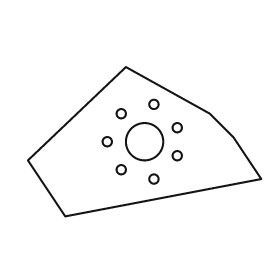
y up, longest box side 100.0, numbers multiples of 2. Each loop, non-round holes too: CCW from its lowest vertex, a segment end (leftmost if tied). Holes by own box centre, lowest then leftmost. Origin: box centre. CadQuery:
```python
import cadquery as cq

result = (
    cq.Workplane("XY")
    .moveTo(-34.0, -32.0)
    .lineTo(50.0, -16.0)
    .lineTo(38.0, 2.0)
    .lineTo(28.0, 12.0)
    .lineTo(-8.0, 32.0)
    .lineTo(-50.0, -8.0)
    .close()
    .moveTo(4.0, -16.0)
    .circle(2.0)
    .moveTo(-10.0, -12.0)
    .circle(2.0)
    .moveTo(14.0, -6.0)
    .circle(2.0)
    .moveTo(-16.0, 0.0)
    .circle(2.0)
    .moveTo(0.0, 0.0)
    .circle(8.0)
    .moveTo(14.0, 6.0)
    .circle(2.0)
    .moveTo(-10.0, 12.0)
    .circle(2.0)
    .moveTo(4.0, 16.0)
    .circle(2.0)
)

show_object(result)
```